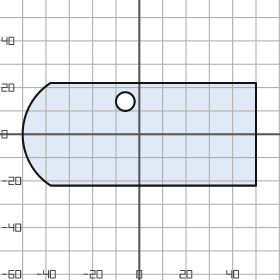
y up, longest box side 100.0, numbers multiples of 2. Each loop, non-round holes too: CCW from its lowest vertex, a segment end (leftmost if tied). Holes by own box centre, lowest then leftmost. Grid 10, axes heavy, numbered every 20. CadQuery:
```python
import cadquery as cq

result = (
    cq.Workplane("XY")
    .moveTo(-38.0, -22.0)
    .lineTo(50.0, -22.0)
    .lineTo(50.0, 22.0)
    .lineTo(-38.0, 22.0)
    .threePointArc((-50.0, 0.0), (-38.0, -22.0))
    .close()
    .moveTo(-6.0, 14.0)
    .circle(4.0)
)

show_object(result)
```